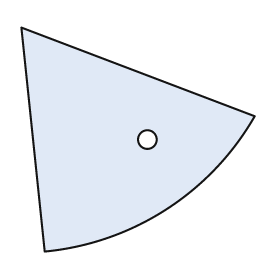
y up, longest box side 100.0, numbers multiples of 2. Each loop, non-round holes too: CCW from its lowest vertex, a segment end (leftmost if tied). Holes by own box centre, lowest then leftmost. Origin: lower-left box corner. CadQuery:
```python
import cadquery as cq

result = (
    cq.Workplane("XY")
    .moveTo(10.0, 0.0)
    .threePointArc((62.0, 18.0), (100.0, 58.0))
    .lineTo(0.0, 96.0)
    .close()
    .moveTo(54.0, 48.0)
    .circle(4.0)
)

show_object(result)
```